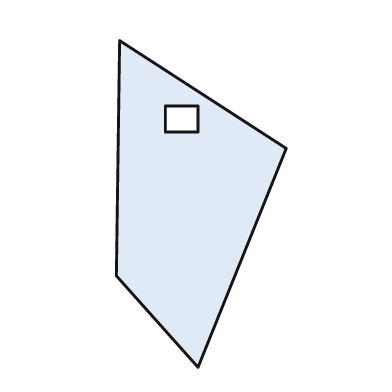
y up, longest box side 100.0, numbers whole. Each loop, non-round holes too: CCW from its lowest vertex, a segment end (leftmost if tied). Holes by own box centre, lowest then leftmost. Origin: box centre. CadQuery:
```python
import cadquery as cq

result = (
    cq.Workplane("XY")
    .moveTo(-1.0, -50.0)
    .lineTo(26.0, 17.0)
    .lineTo(-25.0, 50.0)
    .lineTo(-26.0, -22.0)
    .close()
    .moveTo(-11.0, 22.0)
    .lineTo(-1.0, 22.0)
    .lineTo(-1.0, 30.0)
    .lineTo(-11.0, 30.0)
    .close()
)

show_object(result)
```